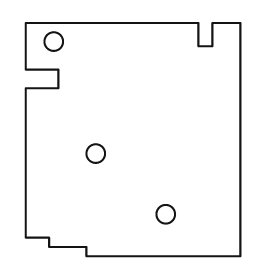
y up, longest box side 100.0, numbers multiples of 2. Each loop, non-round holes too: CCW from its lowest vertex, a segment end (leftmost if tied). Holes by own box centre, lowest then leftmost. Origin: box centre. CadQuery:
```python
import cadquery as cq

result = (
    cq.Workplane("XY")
    .moveTo(-20.0, -50.0)
    .lineTo(46.0, -50.0)
    .lineTo(46.0, 50.0)
    .lineTo(34.0, 50.0)
    .lineTo(34.0, 40.0)
    .lineTo(28.0, 40.0)
    .lineTo(28.0, 50.0)
    .lineTo(-46.0, 50.0)
    .lineTo(-46.0, 30.0)
    .lineTo(-32.0, 30.0)
    .lineTo(-32.0, 22.0)
    .lineTo(-46.0, 22.0)
    .lineTo(-46.0, -42.0)
    .lineTo(-36.0, -42.0)
    .lineTo(-36.0, -46.0)
    .lineTo(-20.0, -46.0)
    .close()
    .moveTo(14.0, -32.0)
    .circle(4.0)
    .moveTo(-16.0, -6.0)
    .circle(4.0)
    .moveTo(-34.0, 42.0)
    .circle(4.0)
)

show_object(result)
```